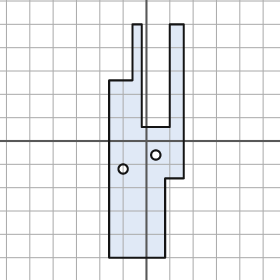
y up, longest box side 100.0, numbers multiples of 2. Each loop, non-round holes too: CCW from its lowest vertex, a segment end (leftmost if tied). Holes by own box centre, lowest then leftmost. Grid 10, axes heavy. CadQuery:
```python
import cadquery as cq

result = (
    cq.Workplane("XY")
    .moveTo(-16.0, -50.0)
    .lineTo(8.0, -50.0)
    .lineTo(8.0, -16.0)
    .lineTo(16.0, -16.0)
    .lineTo(16.0, 50.0)
    .lineTo(10.0, 50.0)
    .lineTo(10.0, 6.0)
    .lineTo(-2.0, 6.0)
    .lineTo(-2.0, 50.0)
    .lineTo(-6.0, 50.0)
    .lineTo(-6.0, 26.0)
    .lineTo(-16.0, 26.0)
    .close()
    .moveTo(-10.0, -12.0)
    .circle(2.0)
    .moveTo(4.0, -6.0)
    .circle(2.0)
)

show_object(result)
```